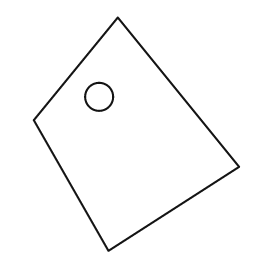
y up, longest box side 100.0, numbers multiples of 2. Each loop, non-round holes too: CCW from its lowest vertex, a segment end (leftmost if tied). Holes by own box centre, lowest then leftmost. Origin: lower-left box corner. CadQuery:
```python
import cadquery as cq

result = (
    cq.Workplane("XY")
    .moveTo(32.0, 0.0)
    .lineTo(88.0, 36.0)
    .lineTo(36.0, 100.0)
    .lineTo(0.0, 56.0)
    .close()
    .moveTo(28.0, 66.0)
    .circle(6.0)
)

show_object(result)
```